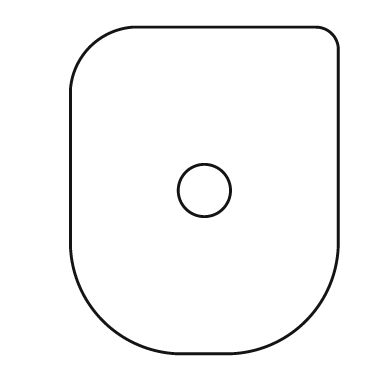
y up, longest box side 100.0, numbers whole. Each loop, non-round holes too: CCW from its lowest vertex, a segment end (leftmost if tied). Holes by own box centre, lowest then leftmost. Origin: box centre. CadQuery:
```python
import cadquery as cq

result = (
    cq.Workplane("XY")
    .moveTo(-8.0, -50.0)
    .lineTo(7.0, -50.0)
    .threePointArc((31.0, -40.0), (41.0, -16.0))
    .lineTo(41.0, 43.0)
    .threePointArc((39.0, 48.0), (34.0, 50.0))
    .lineTo(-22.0, 50.0)
    .threePointArc((-35.0, 44.0), (-41.0, 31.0))
    .lineTo(-41.0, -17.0)
    .threePointArc((-31.0, -40.0), (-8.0, -50.0))
    .close()
    .moveTo(0.0, 0.0)
    .circle(8.0)
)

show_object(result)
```